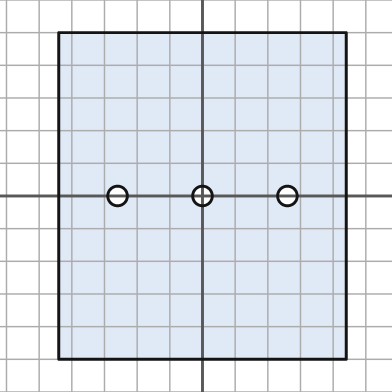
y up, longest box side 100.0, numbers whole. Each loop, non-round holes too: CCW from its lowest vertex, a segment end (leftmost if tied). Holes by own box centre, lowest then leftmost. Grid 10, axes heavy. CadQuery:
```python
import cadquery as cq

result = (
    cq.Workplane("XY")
    .moveTo(-44.0, -50.0)
    .lineTo(44.0, -50.0)
    .lineTo(44.0, 50.0)
    .lineTo(-44.0, 50.0)
    .close()
    .moveTo(-26.0, 0.0)
    .circle(3.0)
    .moveTo(0.0, 0.0)
    .circle(3.0)
    .moveTo(26.0, 0.0)
    .circle(3.0)
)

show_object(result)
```